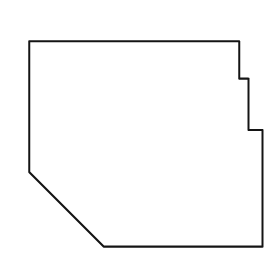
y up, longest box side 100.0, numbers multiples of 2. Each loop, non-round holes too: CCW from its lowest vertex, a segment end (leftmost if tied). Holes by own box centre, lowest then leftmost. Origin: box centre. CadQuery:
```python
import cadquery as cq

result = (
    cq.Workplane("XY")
    .moveTo(-18.0, -44.0)
    .lineTo(50.0, -44.0)
    .lineTo(50.0, 6.0)
    .lineTo(44.0, 6.0)
    .lineTo(44.0, 28.0)
    .lineTo(40.0, 28.0)
    .lineTo(40.0, 44.0)
    .lineTo(-50.0, 44.0)
    .lineTo(-50.0, -12.0)
    .close()
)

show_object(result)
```